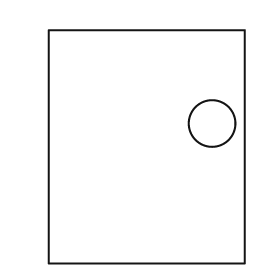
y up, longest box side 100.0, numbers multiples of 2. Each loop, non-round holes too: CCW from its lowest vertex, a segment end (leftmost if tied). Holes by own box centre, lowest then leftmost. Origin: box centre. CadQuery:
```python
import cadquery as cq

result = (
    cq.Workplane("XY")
    .moveTo(-42.0, -50.0)
    .lineTo(42.0, -50.0)
    .lineTo(42.0, 50.0)
    .lineTo(-42.0, 50.0)
    .close()
    .moveTo(28.0, 10.0)
    .circle(10.0)
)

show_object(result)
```